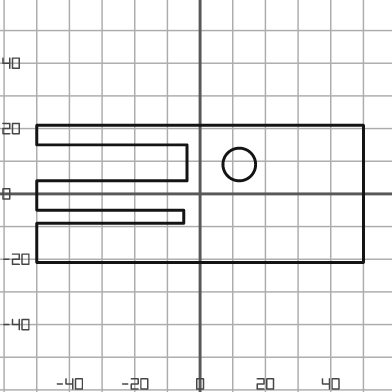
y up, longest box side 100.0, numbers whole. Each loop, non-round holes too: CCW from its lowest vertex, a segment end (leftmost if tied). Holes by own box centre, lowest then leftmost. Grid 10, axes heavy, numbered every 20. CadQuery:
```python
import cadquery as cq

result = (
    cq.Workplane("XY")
    .moveTo(-50.0, -21.0)
    .lineTo(50.0, -21.0)
    .lineTo(50.0, 21.0)
    .lineTo(-50.0, 21.0)
    .lineTo(-50.0, 15.0)
    .lineTo(-4.0, 15.0)
    .lineTo(-4.0, 4.0)
    .lineTo(-50.0, 4.0)
    .lineTo(-50.0, -5.0)
    .lineTo(-5.0, -5.0)
    .lineTo(-5.0, -9.0)
    .lineTo(-50.0, -9.0)
    .close()
    .moveTo(12.0, 9.0)
    .circle(5.0)
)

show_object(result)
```